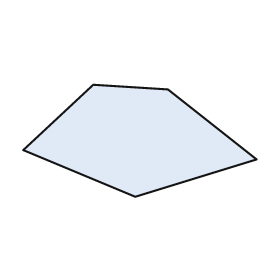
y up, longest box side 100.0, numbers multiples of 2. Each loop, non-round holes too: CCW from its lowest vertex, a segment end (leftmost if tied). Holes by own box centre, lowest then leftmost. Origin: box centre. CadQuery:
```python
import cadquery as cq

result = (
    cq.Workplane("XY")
    .moveTo(-2.0, -24.0)
    .lineTo(50.0, -8.0)
    .lineTo(12.0, 22.0)
    .lineTo(-20.0, 24.0)
    .lineTo(-50.0, -4.0)
    .close()
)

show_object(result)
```